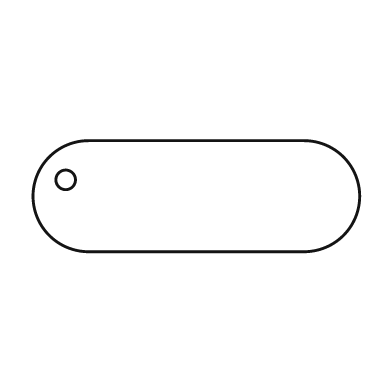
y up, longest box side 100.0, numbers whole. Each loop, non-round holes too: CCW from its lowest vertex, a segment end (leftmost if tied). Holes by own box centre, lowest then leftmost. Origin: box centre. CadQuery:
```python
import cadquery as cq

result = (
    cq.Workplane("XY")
    .moveTo(-33.0, -17.0)
    .lineTo(33.0, -17.0)
    .threePointArc((50.0, 0.0), (33.0, 17.0))
    .lineTo(-33.0, 17.0)
    .threePointArc((-50.0, 0.0), (-33.0, -17.0))
    .close()
    .moveTo(-40.0, 5.0)
    .circle(3.0)
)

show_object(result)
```